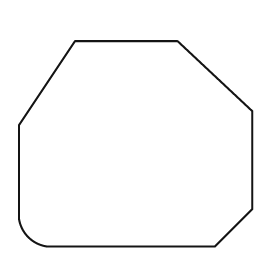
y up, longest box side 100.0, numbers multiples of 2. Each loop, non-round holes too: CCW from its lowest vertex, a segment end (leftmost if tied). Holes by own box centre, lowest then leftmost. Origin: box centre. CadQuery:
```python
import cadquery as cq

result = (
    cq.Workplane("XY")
    .moveTo(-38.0, -44.0)
    .lineTo(34.0, -44.0)
    .lineTo(50.0, -28.0)
    .lineTo(50.0, 14.0)
    .lineTo(18.0, 44.0)
    .lineTo(-26.0, 44.0)
    .lineTo(-50.0, 8.0)
    .lineTo(-50.0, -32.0)
    .threePointArc((-46.0, -40.0), (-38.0, -44.0))
    .close()
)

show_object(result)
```